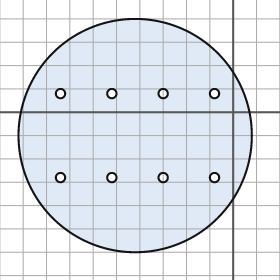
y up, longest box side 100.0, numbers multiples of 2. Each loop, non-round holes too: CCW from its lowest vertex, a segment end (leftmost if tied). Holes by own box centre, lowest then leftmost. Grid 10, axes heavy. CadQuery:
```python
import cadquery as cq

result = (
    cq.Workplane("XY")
    .moveTo(-42.0, -10.0)
    .circle(50.0)
    .moveTo(-74.0, -28.0)
    .circle(2.0)
    .moveTo(-52.0, -28.0)
    .circle(2.0)
    .moveTo(-30.0, -28.0)
    .circle(2.0)
    .moveTo(-8.0, -28.0)
    .circle(2.0)
    .moveTo(-74.0, 8.0)
    .circle(2.0)
    .moveTo(-52.0, 8.0)
    .circle(2.0)
    .moveTo(-30.0, 8.0)
    .circle(2.0)
    .moveTo(-8.0, 8.0)
    .circle(2.0)
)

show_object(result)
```